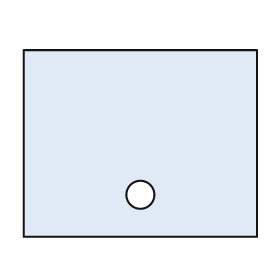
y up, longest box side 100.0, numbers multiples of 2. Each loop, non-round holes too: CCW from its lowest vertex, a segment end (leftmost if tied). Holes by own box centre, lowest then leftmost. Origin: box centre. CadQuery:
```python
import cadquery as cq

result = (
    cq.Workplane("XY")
    .moveTo(-50.0, -40.0)
    .lineTo(50.0, -40.0)
    .lineTo(50.0, 40.0)
    .lineTo(-50.0, 40.0)
    .close()
    .moveTo(0.0, -22.0)
    .circle(6.0)
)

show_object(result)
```